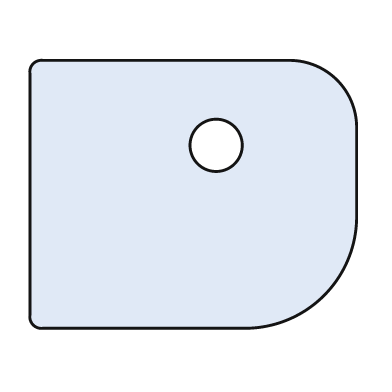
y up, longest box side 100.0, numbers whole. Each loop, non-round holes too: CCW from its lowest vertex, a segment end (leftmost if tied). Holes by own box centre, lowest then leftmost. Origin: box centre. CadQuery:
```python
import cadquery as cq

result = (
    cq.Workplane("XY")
    .moveTo(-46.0, -41.0)
    .lineTo(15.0, -41.0)
    .threePointArc((40.0, -31.0), (50.0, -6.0))
    .lineTo(50.0, 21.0)
    .threePointArc((44.0, 35.0), (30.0, 41.0))
    .lineTo(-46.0, 41.0)
    .threePointArc((-49.0, 40.0), (-50.0, 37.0))
    .lineTo(-50.0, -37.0)
    .threePointArc((-49.0, -40.0), (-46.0, -41.0))
    .close()
    .moveTo(7.0, 15.0)
    .circle(8.0)
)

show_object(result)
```